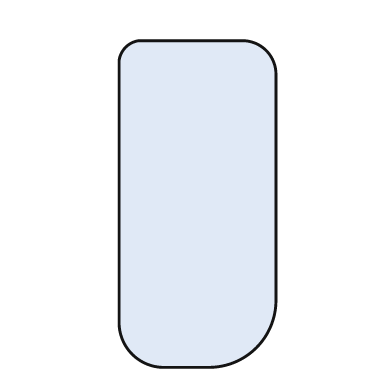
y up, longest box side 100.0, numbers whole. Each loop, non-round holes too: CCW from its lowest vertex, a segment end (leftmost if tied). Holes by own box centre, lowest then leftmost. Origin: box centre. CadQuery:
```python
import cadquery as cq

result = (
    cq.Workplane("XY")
    .moveTo(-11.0, -50.0)
    .lineTo(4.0, -50.0)
    .threePointArc((18.0, -44.0), (24.0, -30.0))
    .lineTo(24.0, 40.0)
    .threePointArc((21.0, 47.0), (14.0, 50.0))
    .lineTo(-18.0, 50.0)
    .threePointArc((-22.0, 48.0), (-24.0, 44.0))
    .lineTo(-24.0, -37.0)
    .threePointArc((-20.0, -46.0), (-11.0, -50.0))
    .close()
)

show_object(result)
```